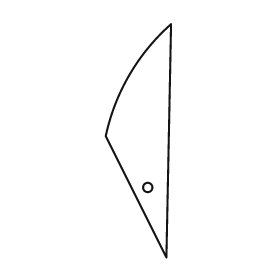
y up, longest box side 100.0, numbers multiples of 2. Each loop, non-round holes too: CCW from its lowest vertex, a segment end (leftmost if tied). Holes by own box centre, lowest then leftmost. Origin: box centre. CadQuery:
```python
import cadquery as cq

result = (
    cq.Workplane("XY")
    .moveTo(12.0, -50.0)
    .lineTo(14.0, 50.0)
    .threePointArc((-4.0, 28.0), (-14.0, 2.0))
    .close()
    .moveTo(4.0, -20.0)
    .circle(2.0)
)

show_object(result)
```